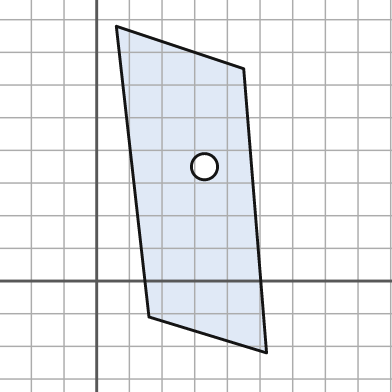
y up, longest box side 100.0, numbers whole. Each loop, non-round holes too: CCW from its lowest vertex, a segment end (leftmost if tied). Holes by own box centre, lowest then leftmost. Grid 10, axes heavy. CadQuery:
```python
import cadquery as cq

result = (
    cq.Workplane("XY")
    .moveTo(52.0, -22.0)
    .lineTo(45.0, 65.0)
    .lineTo(6.0, 78.0)
    .lineTo(16.0, -11.0)
    .close()
    .moveTo(33.0, 35.0)
    .circle(4.0)
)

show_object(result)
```